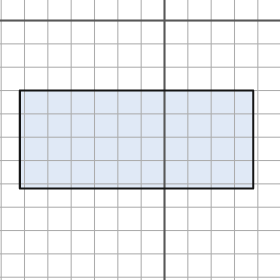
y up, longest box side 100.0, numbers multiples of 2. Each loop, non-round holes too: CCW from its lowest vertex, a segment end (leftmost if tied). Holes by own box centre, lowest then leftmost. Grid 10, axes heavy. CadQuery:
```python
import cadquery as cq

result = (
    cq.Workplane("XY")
    .moveTo(-62.0, -72.0)
    .lineTo(38.0, -72.0)
    .lineTo(38.0, -30.0)
    .lineTo(-62.0, -30.0)
    .close()
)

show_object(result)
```